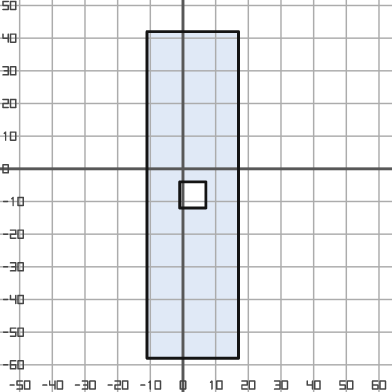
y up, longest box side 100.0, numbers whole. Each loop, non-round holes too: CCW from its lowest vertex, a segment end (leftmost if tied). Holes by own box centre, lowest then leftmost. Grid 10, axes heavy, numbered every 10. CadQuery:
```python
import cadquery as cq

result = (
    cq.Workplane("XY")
    .moveTo(-11.0, -58.0)
    .lineTo(17.0, -58.0)
    .lineTo(17.0, 42.0)
    .lineTo(-11.0, 42.0)
    .close()
    .moveTo(-1.0, -12.0)
    .lineTo(7.0, -12.0)
    .lineTo(7.0, -4.0)
    .lineTo(-1.0, -4.0)
    .close()
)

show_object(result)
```